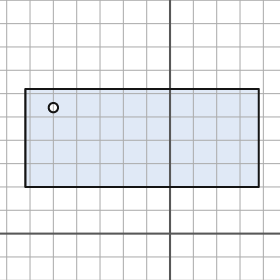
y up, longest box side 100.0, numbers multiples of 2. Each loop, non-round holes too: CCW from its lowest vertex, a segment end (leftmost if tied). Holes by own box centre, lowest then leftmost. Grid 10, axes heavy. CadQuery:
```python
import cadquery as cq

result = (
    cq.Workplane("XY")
    .moveTo(-62.0, 20.0)
    .lineTo(38.0, 20.0)
    .lineTo(38.0, 62.0)
    .lineTo(-62.0, 62.0)
    .close()
    .moveTo(-50.0, 54.0)
    .circle(2.0)
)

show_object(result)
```